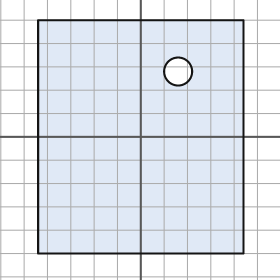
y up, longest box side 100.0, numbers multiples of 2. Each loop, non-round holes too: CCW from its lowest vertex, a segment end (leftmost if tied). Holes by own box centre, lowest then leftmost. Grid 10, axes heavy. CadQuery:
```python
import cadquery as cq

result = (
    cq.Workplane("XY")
    .moveTo(-44.0, -50.0)
    .lineTo(44.0, -50.0)
    .lineTo(44.0, 50.0)
    .lineTo(-44.0, 50.0)
    .close()
    .moveTo(16.0, 28.0)
    .circle(6.0)
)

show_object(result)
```